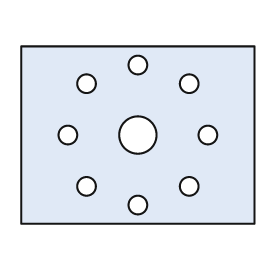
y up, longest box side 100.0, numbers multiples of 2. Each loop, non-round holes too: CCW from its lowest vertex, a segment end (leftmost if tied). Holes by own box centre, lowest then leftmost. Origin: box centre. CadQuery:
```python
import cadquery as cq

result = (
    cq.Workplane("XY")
    .moveTo(-50.0, -38.0)
    .lineTo(50.0, -38.0)
    .lineTo(50.0, 38.0)
    .lineTo(-50.0, 38.0)
    .close()
    .moveTo(0.0, -30.0)
    .circle(4.0)
    .moveTo(-22.0, -22.0)
    .circle(4.0)
    .moveTo(22.0, -22.0)
    .circle(4.0)
    .moveTo(-30.0, 0.0)
    .circle(4.0)
    .moveTo(0.0, 0.0)
    .circle(8.0)
    .moveTo(30.0, 0.0)
    .circle(4.0)
    .moveTo(-22.0, 22.0)
    .circle(4.0)
    .moveTo(22.0, 22.0)
    .circle(4.0)
    .moveTo(0.0, 30.0)
    .circle(4.0)
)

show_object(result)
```